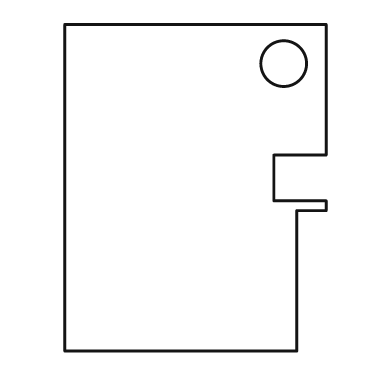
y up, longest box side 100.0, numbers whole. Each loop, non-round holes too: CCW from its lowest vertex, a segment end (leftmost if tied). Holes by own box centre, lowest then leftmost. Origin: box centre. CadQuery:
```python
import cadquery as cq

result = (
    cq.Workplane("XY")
    .moveTo(-40.0, -50.0)
    .lineTo(31.0, -50.0)
    .lineTo(31.0, -7.0)
    .lineTo(40.0, -7.0)
    .lineTo(40.0, -4.0)
    .lineTo(24.0, -4.0)
    .lineTo(24.0, 10.0)
    .lineTo(40.0, 10.0)
    .lineTo(40.0, 50.0)
    .lineTo(-40.0, 50.0)
    .close()
    .moveTo(27.0, 38.0)
    .circle(7.0)
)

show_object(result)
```